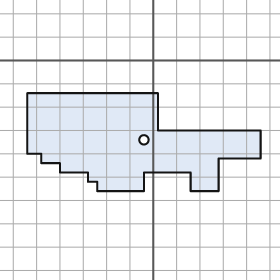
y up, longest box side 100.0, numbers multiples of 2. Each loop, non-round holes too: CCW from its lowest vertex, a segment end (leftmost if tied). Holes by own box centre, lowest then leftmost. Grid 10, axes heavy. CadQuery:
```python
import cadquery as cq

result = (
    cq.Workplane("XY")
    .moveTo(-24.0, -56.0)
    .lineTo(-4.0, -56.0)
    .lineTo(-4.0, -48.0)
    .lineTo(16.0, -48.0)
    .lineTo(16.0, -56.0)
    .lineTo(28.0, -56.0)
    .lineTo(28.0, -42.0)
    .lineTo(46.0, -42.0)
    .lineTo(46.0, -30.0)
    .lineTo(2.0, -30.0)
    .lineTo(2.0, -14.0)
    .lineTo(-54.0, -14.0)
    .lineTo(-54.0, -40.0)
    .lineTo(-48.0, -40.0)
    .lineTo(-48.0, -44.0)
    .lineTo(-40.0, -44.0)
    .lineTo(-40.0, -48.0)
    .lineTo(-28.0, -48.0)
    .lineTo(-28.0, -52.0)
    .lineTo(-24.0, -52.0)
    .close()
    .moveTo(-4.0, -34.0)
    .circle(2.0)
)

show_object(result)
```